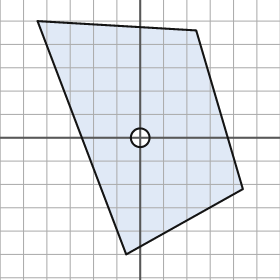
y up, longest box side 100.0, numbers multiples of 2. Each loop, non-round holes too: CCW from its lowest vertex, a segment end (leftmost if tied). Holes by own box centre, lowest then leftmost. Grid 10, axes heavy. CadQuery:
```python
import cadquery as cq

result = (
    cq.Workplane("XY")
    .moveTo(-6.0, -50.0)
    .lineTo(44.0, -22.0)
    .lineTo(24.0, 46.0)
    .lineTo(-44.0, 50.0)
    .close()
    .moveTo(0.0, 0.0)
    .circle(4.0)
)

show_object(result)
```